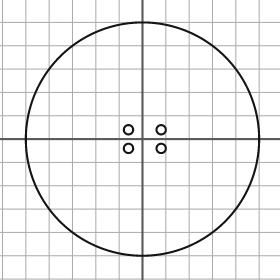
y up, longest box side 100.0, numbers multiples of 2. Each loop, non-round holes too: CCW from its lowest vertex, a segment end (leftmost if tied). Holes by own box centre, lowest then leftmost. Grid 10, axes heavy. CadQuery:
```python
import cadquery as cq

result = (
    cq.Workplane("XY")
    .moveTo(0.0, 0.0)
    .circle(50.0)
    .moveTo(-6.0, -4.0)
    .circle(2.0)
    .moveTo(8.0, -4.0)
    .circle(2.0)
    .moveTo(-6.0, 4.0)
    .circle(2.0)
    .moveTo(8.0, 4.0)
    .circle(2.0)
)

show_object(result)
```